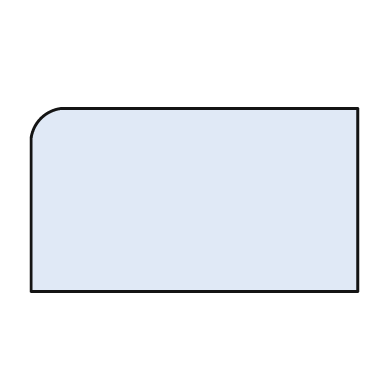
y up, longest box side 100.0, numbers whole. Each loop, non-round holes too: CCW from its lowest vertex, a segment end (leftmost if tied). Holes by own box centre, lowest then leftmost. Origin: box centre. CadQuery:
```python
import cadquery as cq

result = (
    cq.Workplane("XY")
    .moveTo(-50.0, -28.0)
    .lineTo(50.0, -28.0)
    .lineTo(50.0, 28.0)
    .lineTo(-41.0, 28.0)
    .threePointArc((-47.0, 25.0), (-50.0, 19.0))
    .close()
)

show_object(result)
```